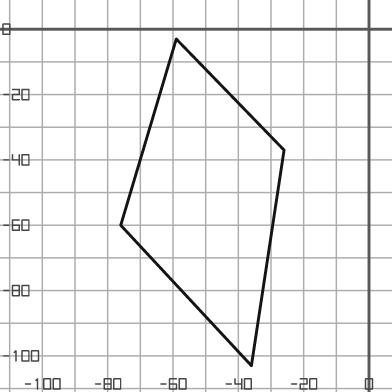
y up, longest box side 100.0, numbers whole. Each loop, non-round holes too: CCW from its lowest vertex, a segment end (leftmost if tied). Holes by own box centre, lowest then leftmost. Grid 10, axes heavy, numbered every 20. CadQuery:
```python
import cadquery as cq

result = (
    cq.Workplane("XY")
    .moveTo(-36.0, -103.0)
    .lineTo(-26.0, -37.0)
    .lineTo(-59.0, -3.0)
    .lineTo(-76.0, -60.0)
    .close()
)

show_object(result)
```